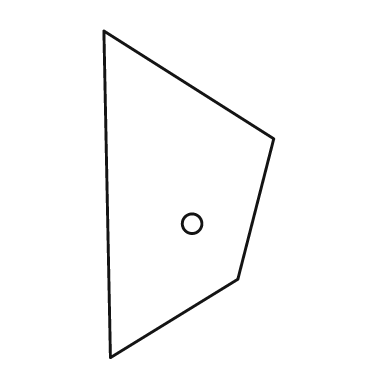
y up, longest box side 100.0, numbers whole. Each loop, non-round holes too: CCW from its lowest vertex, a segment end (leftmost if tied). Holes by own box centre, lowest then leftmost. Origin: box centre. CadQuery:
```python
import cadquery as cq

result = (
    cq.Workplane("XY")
    .moveTo(-24.0, -50.0)
    .lineTo(15.0, -26.0)
    .lineTo(26.0, 17.0)
    .lineTo(-26.0, 50.0)
    .close()
    .moveTo(1.0, -9.0)
    .circle(3.0)
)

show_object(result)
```